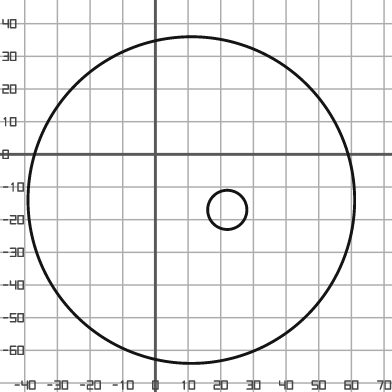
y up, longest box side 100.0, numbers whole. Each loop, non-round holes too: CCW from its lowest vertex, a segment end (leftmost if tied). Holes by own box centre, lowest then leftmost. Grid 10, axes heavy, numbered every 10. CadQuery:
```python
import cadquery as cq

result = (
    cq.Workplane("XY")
    .moveTo(11.0, -14.0)
    .circle(50.0)
    .moveTo(22.0, -17.0)
    .circle(6.0)
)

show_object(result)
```